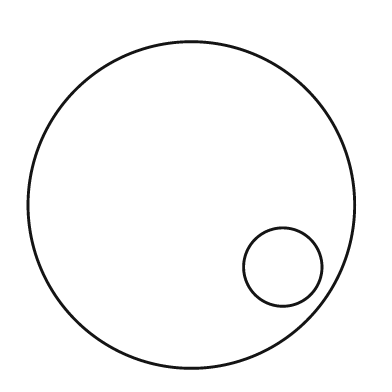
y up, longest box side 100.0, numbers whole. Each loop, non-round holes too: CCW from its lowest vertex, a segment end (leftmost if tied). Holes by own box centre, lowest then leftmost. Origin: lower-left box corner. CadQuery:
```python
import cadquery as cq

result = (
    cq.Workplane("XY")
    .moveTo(50.0, 50.0)
    .circle(50.0)
    .moveTo(78.0, 31.0)
    .circle(12.0)
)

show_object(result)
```